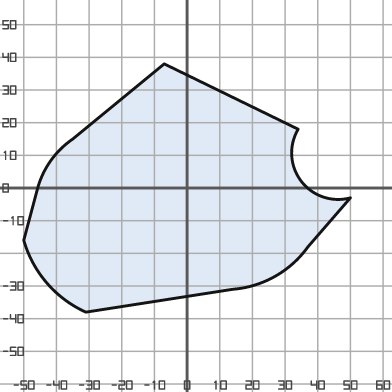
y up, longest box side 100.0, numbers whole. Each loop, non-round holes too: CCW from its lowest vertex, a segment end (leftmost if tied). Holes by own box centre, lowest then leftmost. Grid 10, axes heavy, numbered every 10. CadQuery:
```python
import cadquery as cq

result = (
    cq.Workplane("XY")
    .moveTo(-31.0, -38.0)
    .lineTo(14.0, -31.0)
    .threePointArc((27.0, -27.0), (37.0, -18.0))
    .lineTo(50.0, -3.0)
    .threePointArc((35.0, 2.0), (34.0, 18.0))
    .lineTo(-7.0, 38.0)
    .lineTo(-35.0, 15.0)
    .threePointArc((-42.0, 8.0), (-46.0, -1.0))
    .lineTo(-50.0, -16.0)
    .threePointArc((-43.0, -29.0), (-31.0, -38.0))
    .close()
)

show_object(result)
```